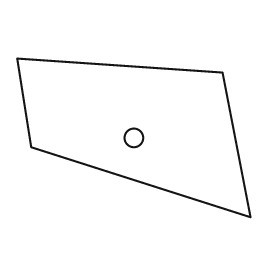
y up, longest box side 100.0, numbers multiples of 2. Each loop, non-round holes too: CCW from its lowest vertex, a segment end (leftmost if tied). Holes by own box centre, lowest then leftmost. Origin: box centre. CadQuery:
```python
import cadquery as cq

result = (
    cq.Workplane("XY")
    .moveTo(50.0, -34.0)
    .lineTo(38.0, 28.0)
    .lineTo(-50.0, 34.0)
    .lineTo(-44.0, -4.0)
    .close()
    .moveTo(0.0, 0.0)
    .circle(4.0)
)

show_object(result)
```